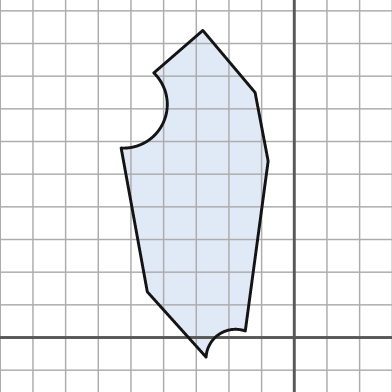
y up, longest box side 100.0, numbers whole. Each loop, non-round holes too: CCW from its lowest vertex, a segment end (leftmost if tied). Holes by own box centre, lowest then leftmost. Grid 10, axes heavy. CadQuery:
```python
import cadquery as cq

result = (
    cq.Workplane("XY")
    .moveTo(-27.0, -6.0)
    .threePointArc((-23.0, 1.0), (-15.0, 2.0))
    .lineTo(-8.0, 54.0)
    .lineTo(-12.0, 75.0)
    .lineTo(-28.0, 94.0)
    .lineTo(-43.0, 81.0)
    .threePointArc((-40.0, 66.0), (-53.0, 58.0))
    .lineTo(-45.0, 14.0)
    .close()
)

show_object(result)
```